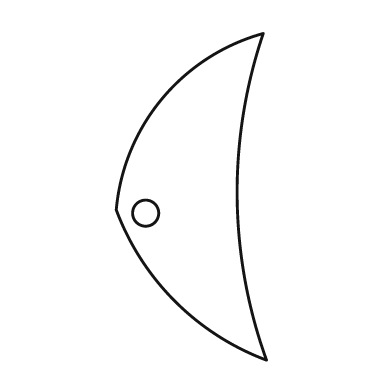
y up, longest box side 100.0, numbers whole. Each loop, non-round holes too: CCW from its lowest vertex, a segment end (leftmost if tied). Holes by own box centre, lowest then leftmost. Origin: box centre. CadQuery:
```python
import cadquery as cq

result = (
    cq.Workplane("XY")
    .moveTo(23.0, -50.0)
    .threePointArc((14.0, 0.0), (22.0, 50.0))
    .threePointArc((-9.0, 30.0), (-23.0, -4.0))
    .threePointArc((-5.0, -32.0), (23.0, -50.0))
    .close()
    .moveTo(-14.0, -5.0)
    .circle(4.0)
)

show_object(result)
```